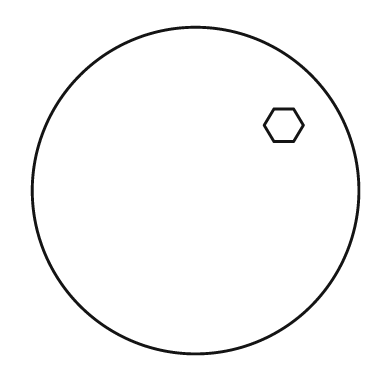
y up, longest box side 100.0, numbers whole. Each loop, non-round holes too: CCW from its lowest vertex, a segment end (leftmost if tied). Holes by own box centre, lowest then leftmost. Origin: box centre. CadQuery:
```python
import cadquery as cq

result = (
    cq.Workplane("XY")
    .moveTo(0.0, 0.0)
    .circle(50.0)
    .moveTo(24.0, 15.0)
    .lineTo(30.0, 15.0)
    .lineTo(33.0, 20.0)
    .lineTo(30.0, 25.0)
    .lineTo(24.0, 25.0)
    .lineTo(21.0, 20.0)
    .close()
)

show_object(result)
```